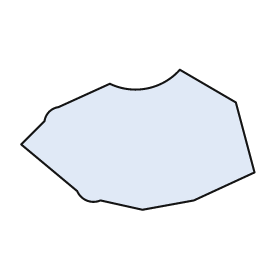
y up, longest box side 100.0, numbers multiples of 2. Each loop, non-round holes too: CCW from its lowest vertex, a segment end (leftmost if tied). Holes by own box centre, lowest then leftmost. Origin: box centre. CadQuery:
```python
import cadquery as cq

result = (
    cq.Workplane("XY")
    .moveTo(2.0, -30.0)
    .lineTo(24.0, -26.0)
    .lineTo(50.0, -14.0)
    .lineTo(42.0, 16.0)
    .lineTo(18.0, 30.0)
    .threePointArc((4.0, 22.0), (-12.0, 24.0))
    .lineTo(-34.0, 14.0)
    .threePointArc((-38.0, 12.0), (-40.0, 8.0))
    .lineTo(-50.0, -2.0)
    .lineTo(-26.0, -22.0)
    .threePointArc((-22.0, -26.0), (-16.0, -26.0))
    .close()
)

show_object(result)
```